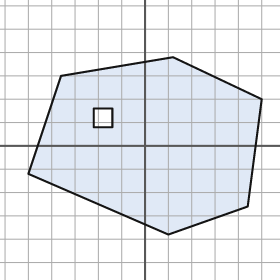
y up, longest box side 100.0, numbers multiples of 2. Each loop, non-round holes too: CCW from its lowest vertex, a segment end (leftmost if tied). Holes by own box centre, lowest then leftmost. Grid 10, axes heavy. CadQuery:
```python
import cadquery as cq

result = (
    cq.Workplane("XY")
    .moveTo(10.0, -38.0)
    .lineTo(44.0, -26.0)
    .lineTo(50.0, 20.0)
    .lineTo(12.0, 38.0)
    .lineTo(-36.0, 30.0)
    .lineTo(-50.0, -12.0)
    .close()
    .moveTo(-22.0, 8.0)
    .lineTo(-14.0, 8.0)
    .lineTo(-14.0, 16.0)
    .lineTo(-22.0, 16.0)
    .close()
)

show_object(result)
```